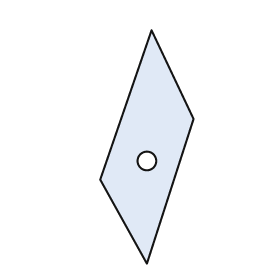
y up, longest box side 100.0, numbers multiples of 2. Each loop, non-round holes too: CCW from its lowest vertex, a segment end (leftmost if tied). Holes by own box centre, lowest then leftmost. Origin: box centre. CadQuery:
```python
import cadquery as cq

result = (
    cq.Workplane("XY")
    .moveTo(0.0, -50.0)
    .lineTo(20.0, 12.0)
    .lineTo(2.0, 50.0)
    .lineTo(-20.0, -14.0)
    .close()
    .moveTo(0.0, -6.0)
    .circle(4.0)
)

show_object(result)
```